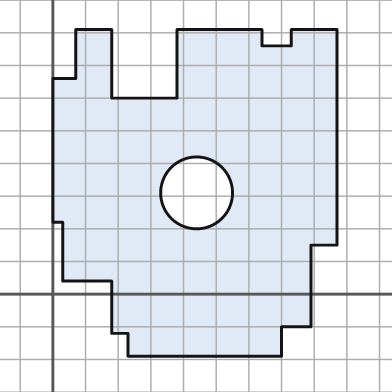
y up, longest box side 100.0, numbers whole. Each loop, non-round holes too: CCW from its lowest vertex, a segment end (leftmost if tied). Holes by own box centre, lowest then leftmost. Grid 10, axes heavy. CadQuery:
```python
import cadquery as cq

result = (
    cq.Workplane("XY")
    .moveTo(23.0, -19.0)
    .lineTo(70.0, -19.0)
    .lineTo(70.0, -10.0)
    .lineTo(79.0, -10.0)
    .lineTo(79.0, 15.0)
    .lineTo(87.0, 15.0)
    .lineTo(87.0, 81.0)
    .lineTo(73.0, 81.0)
    .lineTo(73.0, 76.0)
    .lineTo(64.0, 76.0)
    .lineTo(64.0, 81.0)
    .lineTo(38.0, 81.0)
    .lineTo(38.0, 60.0)
    .lineTo(18.0, 60.0)
    .lineTo(18.0, 81.0)
    .lineTo(7.0, 81.0)
    .lineTo(7.0, 66.0)
    .lineTo(0.0, 66.0)
    .lineTo(0.0, 22.0)
    .lineTo(3.0, 22.0)
    .lineTo(3.0, 4.0)
    .lineTo(18.0, 4.0)
    .lineTo(18.0, -12.0)
    .lineTo(23.0, -12.0)
    .close()
    .moveTo(44.0, 31.0)
    .circle(11.0)
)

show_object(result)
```